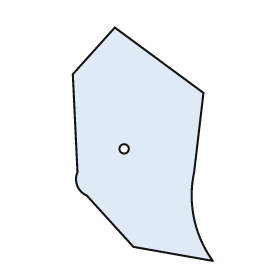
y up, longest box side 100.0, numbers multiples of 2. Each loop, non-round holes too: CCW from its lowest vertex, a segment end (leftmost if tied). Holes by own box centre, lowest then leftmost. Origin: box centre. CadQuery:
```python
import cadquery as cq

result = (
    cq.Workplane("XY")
    .moveTo(30.0, -50.0)
    .threePointArc((22.0, -32.0), (22.0, -12.0))
    .lineTo(26.0, 22.0)
    .lineTo(-12.0, 50.0)
    .lineTo(-30.0, 30.0)
    .lineTo(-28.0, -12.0)
    .threePointArc((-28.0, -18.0), (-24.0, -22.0))
    .lineTo(-4.0, -44.0)
    .close()
    .moveTo(-8.0, -2.0)
    .circle(2.0)
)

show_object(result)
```